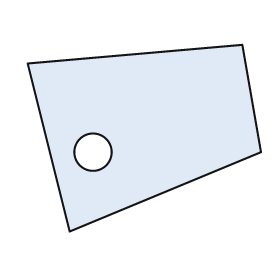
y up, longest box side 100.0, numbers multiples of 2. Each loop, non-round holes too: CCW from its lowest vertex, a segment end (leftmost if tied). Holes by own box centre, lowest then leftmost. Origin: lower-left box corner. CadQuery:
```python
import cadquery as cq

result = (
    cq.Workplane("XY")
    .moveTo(18.0, 0.0)
    .lineTo(100.0, 34.0)
    .lineTo(92.0, 80.0)
    .lineTo(0.0, 72.0)
    .close()
    .moveTo(28.0, 34.0)
    .circle(8.0)
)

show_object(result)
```